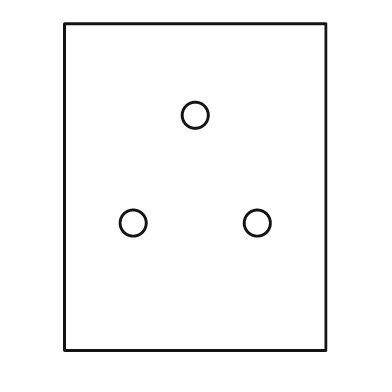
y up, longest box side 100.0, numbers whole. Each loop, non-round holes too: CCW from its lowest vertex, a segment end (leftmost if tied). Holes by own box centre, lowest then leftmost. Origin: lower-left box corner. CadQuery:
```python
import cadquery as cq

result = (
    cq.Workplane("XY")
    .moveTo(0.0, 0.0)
    .lineTo(80.0, 0.0)
    .lineTo(80.0, 100.0)
    .lineTo(0.0, 100.0)
    .close()
    .moveTo(21.0, 39.0)
    .circle(4.0)
    .moveTo(59.0, 39.0)
    .circle(4.0)
    .moveTo(40.0, 72.0)
    .circle(4.0)
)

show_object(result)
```